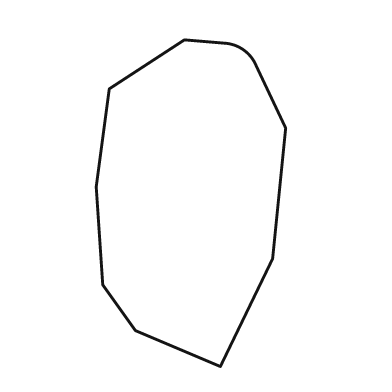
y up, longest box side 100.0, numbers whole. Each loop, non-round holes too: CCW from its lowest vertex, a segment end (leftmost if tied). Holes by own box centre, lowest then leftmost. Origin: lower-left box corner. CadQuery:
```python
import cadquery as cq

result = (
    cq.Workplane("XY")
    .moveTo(38.0, 0.0)
    .lineTo(54.0, 33.0)
    .lineTo(58.0, 73.0)
    .lineTo(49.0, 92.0)
    .threePointArc((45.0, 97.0), (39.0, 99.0))
    .lineTo(27.0, 100.0)
    .lineTo(4.0, 85.0)
    .lineTo(0.0, 55.0)
    .lineTo(2.0, 25.0)
    .lineTo(12.0, 11.0)
    .close()
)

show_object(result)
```